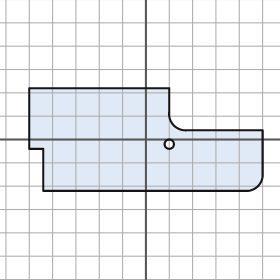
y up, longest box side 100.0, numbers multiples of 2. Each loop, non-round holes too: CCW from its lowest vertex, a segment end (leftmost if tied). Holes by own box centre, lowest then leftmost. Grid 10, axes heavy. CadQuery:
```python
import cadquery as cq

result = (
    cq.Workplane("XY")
    .moveTo(-44.0, -22.0)
    .lineTo(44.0, -22.0)
    .threePointArc((48.0, -20.0), (50.0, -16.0))
    .lineTo(50.0, 4.0)
    .lineTo(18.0, 4.0)
    .threePointArc((12.0, 6.0), (10.0, 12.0))
    .lineTo(10.0, 22.0)
    .lineTo(-50.0, 22.0)
    .lineTo(-50.0, -4.0)
    .lineTo(-44.0, -4.0)
    .close()
    .moveTo(10.0, -2.0)
    .circle(2.0)
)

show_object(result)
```